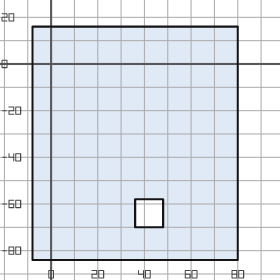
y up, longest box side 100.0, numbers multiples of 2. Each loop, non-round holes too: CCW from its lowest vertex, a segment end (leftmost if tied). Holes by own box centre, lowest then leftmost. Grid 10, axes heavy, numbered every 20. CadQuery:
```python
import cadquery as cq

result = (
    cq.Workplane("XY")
    .moveTo(-8.0, -84.0)
    .lineTo(80.0, -84.0)
    .lineTo(80.0, 16.0)
    .lineTo(-8.0, 16.0)
    .close()
    .moveTo(36.0, -70.0)
    .lineTo(48.0, -70.0)
    .lineTo(48.0, -58.0)
    .lineTo(36.0, -58.0)
    .close()
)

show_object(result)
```